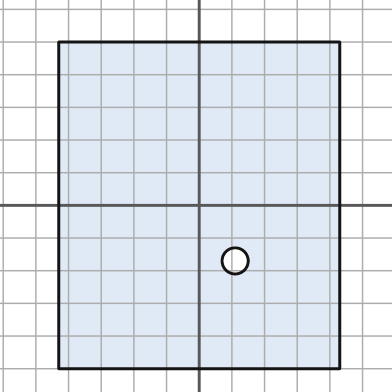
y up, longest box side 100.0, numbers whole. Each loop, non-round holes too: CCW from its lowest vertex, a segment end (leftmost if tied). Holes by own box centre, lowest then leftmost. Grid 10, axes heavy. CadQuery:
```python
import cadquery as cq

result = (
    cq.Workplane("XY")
    .moveTo(-43.0, -50.0)
    .lineTo(43.0, -50.0)
    .lineTo(43.0, 50.0)
    .lineTo(-43.0, 50.0)
    .close()
    .moveTo(11.0, -17.0)
    .circle(4.0)
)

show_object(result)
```